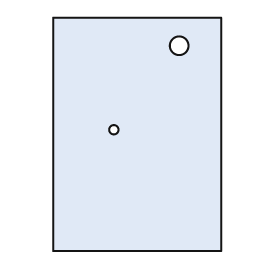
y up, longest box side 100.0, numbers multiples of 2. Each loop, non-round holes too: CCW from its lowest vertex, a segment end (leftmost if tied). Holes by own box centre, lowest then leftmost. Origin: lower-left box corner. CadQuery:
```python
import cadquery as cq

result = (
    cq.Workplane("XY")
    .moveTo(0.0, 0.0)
    .lineTo(72.0, 0.0)
    .lineTo(72.0, 100.0)
    .lineTo(0.0, 100.0)
    .close()
    .moveTo(26.0, 52.0)
    .circle(2.0)
    .moveTo(54.0, 88.0)
    .circle(4.0)
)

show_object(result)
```